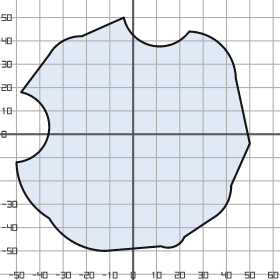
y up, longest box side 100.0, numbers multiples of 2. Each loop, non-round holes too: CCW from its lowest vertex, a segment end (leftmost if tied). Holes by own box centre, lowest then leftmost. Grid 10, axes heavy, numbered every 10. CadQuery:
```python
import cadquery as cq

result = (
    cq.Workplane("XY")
    .moveTo(-12.0, -50.0)
    .lineTo(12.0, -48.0)
    .threePointArc((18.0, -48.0), (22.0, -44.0))
    .lineTo(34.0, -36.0)
    .threePointArc((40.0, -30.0), (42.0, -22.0))
    .lineTo(50.0, -4.0)
    .lineTo(44.0, 24.0)
    .threePointArc((38.0, 38.0), (24.0, 44.0))
    .threePointArc((8.0, 38.0), (-4.0, 50.0))
    .lineTo(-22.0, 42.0)
    .threePointArc((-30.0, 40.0), (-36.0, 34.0))
    .lineTo(-48.0, 18.0)
    .threePointArc((-36.0, 2.0), (-50.0, -12.0))
    .threePointArc((-46.0, -26.0), (-36.0, -36.0))
    .threePointArc((-26.0, -46.0), (-12.0, -50.0))
    .close()
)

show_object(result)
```